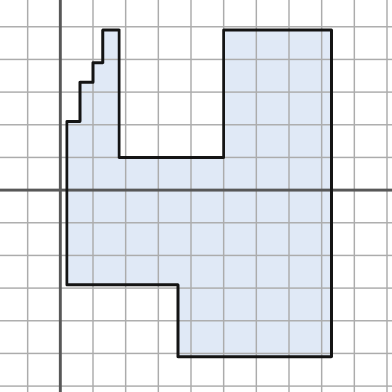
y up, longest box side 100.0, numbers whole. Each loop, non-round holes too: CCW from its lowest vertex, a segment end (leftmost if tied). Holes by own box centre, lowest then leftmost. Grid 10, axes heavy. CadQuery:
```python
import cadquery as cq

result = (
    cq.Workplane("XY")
    .moveTo(36.0, -51.0)
    .lineTo(83.0, -51.0)
    .lineTo(83.0, 49.0)
    .lineTo(50.0, 49.0)
    .lineTo(50.0, 10.0)
    .lineTo(18.0, 10.0)
    .lineTo(18.0, 49.0)
    .lineTo(13.0, 49.0)
    .lineTo(13.0, 39.0)
    .lineTo(10.0, 39.0)
    .lineTo(10.0, 33.0)
    .lineTo(6.0, 33.0)
    .lineTo(6.0, 21.0)
    .lineTo(2.0, 21.0)
    .lineTo(2.0, -29.0)
    .lineTo(36.0, -29.0)
    .close()
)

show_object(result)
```